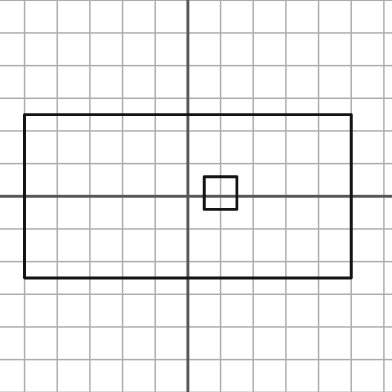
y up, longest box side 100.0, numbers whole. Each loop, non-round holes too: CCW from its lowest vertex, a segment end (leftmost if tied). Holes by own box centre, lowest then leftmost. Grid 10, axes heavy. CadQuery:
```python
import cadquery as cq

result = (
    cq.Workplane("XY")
    .moveTo(-50.0, -25.0)
    .lineTo(50.0, -25.0)
    .lineTo(50.0, 25.0)
    .lineTo(-50.0, 25.0)
    .close()
    .moveTo(5.0, -4.0)
    .lineTo(15.0, -4.0)
    .lineTo(15.0, 6.0)
    .lineTo(5.0, 6.0)
    .close()
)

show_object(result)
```